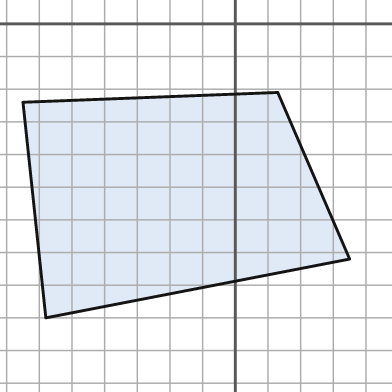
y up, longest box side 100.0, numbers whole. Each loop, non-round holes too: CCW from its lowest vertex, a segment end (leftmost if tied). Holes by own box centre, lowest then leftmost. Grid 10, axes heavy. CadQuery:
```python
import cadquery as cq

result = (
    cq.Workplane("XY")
    .moveTo(-58.0, -90.0)
    .lineTo(35.0, -72.0)
    .lineTo(13.0, -21.0)
    .lineTo(-65.0, -24.0)
    .close()
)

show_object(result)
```